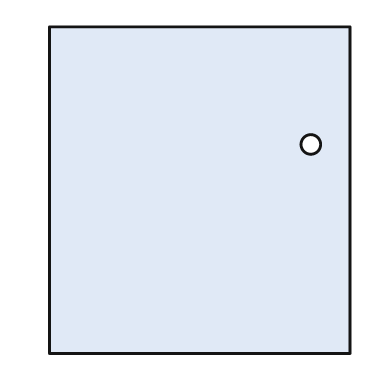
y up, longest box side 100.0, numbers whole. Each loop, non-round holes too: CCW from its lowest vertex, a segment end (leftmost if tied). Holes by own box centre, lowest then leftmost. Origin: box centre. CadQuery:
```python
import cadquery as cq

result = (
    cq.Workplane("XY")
    .moveTo(-46.0, -50.0)
    .lineTo(46.0, -50.0)
    .lineTo(46.0, 50.0)
    .lineTo(-46.0, 50.0)
    .close()
    .moveTo(34.0, 14.0)
    .circle(3.0)
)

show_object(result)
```